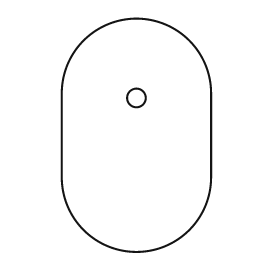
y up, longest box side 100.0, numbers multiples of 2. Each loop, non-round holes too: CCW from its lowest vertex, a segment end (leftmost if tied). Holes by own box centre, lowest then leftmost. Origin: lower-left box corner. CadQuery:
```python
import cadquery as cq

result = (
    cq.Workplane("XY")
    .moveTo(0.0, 32.0)
    .threePointArc((32.0, 0.0), (64.0, 32.0))
    .lineTo(64.0, 68.0)
    .threePointArc((32.0, 100.0), (0.0, 68.0))
    .close()
    .moveTo(32.0, 66.0)
    .circle(4.0)
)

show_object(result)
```